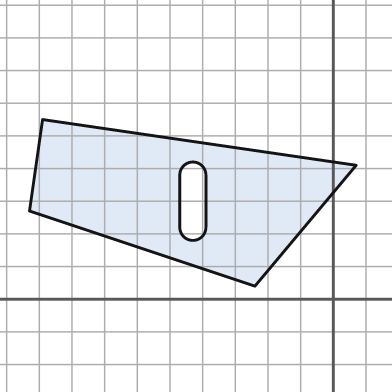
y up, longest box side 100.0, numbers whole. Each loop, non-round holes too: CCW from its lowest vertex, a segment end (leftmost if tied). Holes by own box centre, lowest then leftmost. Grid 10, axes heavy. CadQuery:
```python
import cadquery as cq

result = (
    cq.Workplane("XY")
    .moveTo(-24.0, 4.0)
    .lineTo(7.0, 41.0)
    .lineTo(-89.0, 55.0)
    .lineTo(-93.0, 27.0)
    .close()
    .moveTo(-47.0, 22.0)
    .threePointArc((-43.0, 18.0), (-39.0, 22.0))
    .lineTo(-39.0, 38.0)
    .threePointArc((-43.0, 42.0), (-47.0, 38.0))
    .close()
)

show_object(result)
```